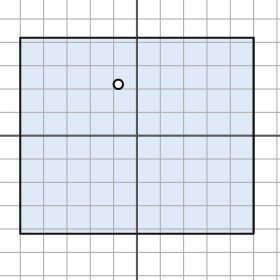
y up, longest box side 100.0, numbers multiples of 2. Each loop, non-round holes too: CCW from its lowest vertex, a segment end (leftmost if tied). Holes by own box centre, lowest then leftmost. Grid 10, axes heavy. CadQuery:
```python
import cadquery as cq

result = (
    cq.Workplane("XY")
    .moveTo(-50.0, -42.0)
    .lineTo(50.0, -42.0)
    .lineTo(50.0, 42.0)
    .lineTo(-50.0, 42.0)
    .close()
    .moveTo(-8.0, 22.0)
    .circle(2.0)
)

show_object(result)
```